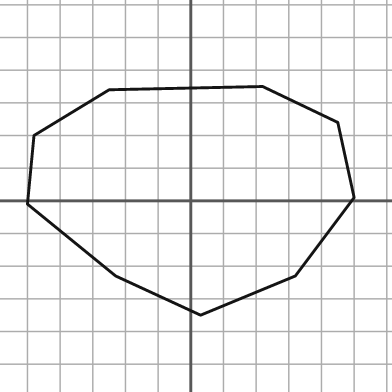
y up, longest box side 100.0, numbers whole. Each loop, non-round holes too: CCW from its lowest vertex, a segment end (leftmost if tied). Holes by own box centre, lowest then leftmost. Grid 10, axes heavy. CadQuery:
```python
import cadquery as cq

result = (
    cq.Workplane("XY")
    .moveTo(3.0, -35.0)
    .lineTo(32.0, -23.0)
    .lineTo(50.0, 1.0)
    .lineTo(45.0, 24.0)
    .lineTo(22.0, 35.0)
    .lineTo(-25.0, 34.0)
    .lineTo(-48.0, 20.0)
    .lineTo(-50.0, -1.0)
    .lineTo(-23.0, -23.0)
    .close()
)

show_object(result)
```